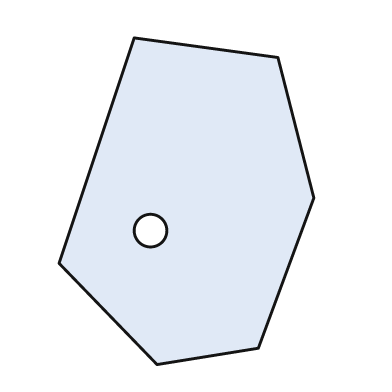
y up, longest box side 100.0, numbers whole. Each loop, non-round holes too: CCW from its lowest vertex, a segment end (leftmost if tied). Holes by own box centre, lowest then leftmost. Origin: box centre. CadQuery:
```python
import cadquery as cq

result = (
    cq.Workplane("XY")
    .moveTo(-9.0, -50.0)
    .lineTo(22.0, -45.0)
    .lineTo(39.0, 1.0)
    .lineTo(28.0, 44.0)
    .lineTo(-16.0, 50.0)
    .lineTo(-39.0, -19.0)
    .close()
    .moveTo(-11.0, -9.0)
    .circle(5.0)
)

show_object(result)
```